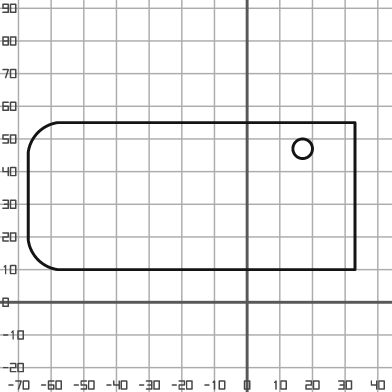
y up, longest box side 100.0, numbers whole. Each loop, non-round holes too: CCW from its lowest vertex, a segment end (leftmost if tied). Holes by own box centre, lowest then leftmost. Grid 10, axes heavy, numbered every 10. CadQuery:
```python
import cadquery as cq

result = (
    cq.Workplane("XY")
    .moveTo(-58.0, 10.0)
    .lineTo(33.0, 10.0)
    .lineTo(33.0, 55.0)
    .lineTo(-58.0, 55.0)
    .threePointArc((-64.0, 52.0), (-67.0, 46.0))
    .lineTo(-67.0, 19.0)
    .threePointArc((-64.0, 13.0), (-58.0, 10.0))
    .close()
    .moveTo(17.0, 47.0)
    .circle(3.0)
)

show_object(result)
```